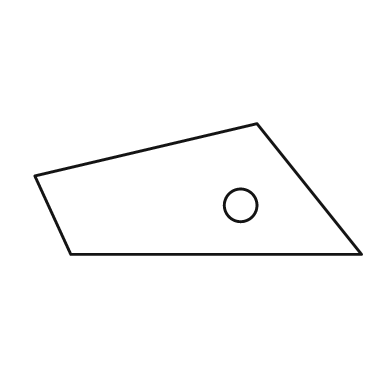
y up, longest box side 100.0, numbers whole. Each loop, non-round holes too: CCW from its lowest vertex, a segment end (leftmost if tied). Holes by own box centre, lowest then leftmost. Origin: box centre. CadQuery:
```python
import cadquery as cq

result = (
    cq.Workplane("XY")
    .moveTo(-39.0, -20.0)
    .lineTo(50.0, -20.0)
    .lineTo(18.0, 20.0)
    .lineTo(-50.0, 4.0)
    .close()
    .moveTo(13.0, -5.0)
    .circle(5.0)
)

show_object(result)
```